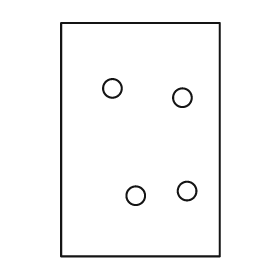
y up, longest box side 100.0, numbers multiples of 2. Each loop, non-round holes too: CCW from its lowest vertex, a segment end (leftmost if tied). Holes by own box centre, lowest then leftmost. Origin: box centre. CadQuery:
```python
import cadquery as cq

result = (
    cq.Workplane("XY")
    .moveTo(-34.0, -50.0)
    .lineTo(34.0, -50.0)
    .lineTo(34.0, 50.0)
    .lineTo(-34.0, 50.0)
    .close()
    .moveTo(-2.0, -24.0)
    .circle(4.0)
    .moveTo(20.0, -22.0)
    .circle(4.0)
    .moveTo(18.0, 18.0)
    .circle(4.0)
    .moveTo(-12.0, 22.0)
    .circle(4.0)
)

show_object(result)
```